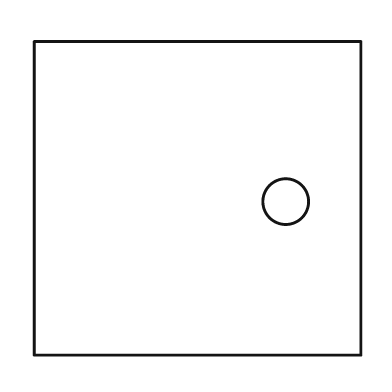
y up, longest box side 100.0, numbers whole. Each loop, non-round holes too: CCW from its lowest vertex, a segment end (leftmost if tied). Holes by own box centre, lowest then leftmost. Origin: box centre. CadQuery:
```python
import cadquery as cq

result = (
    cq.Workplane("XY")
    .moveTo(-50.0, -48.0)
    .lineTo(50.0, -48.0)
    .lineTo(50.0, 48.0)
    .lineTo(-50.0, 48.0)
    .close()
    .moveTo(27.0, -1.0)
    .circle(7.0)
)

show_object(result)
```